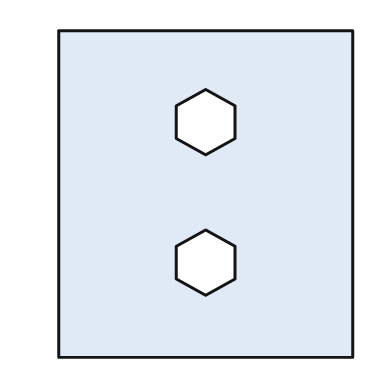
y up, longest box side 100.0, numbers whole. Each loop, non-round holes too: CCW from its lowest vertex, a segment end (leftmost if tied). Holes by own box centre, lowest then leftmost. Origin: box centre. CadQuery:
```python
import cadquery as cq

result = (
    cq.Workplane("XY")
    .moveTo(-45.0, -50.0)
    .lineTo(45.0, -50.0)
    .lineTo(45.0, 50.0)
    .lineTo(-45.0, 50.0)
    .close()
    .moveTo(0.0, -31.0)
    .lineTo(9.0, -26.0)
    .lineTo(9.0, -16.0)
    .lineTo(0.0, -11.0)
    .lineTo(-9.0, -16.0)
    .lineTo(-9.0, -26.0)
    .close()
    .moveTo(0.0, 12.0)
    .lineTo(9.0, 17.0)
    .lineTo(9.0, 27.0)
    .lineTo(0.0, 32.0)
    .lineTo(-9.0, 27.0)
    .lineTo(-9.0, 17.0)
    .close()
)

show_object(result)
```